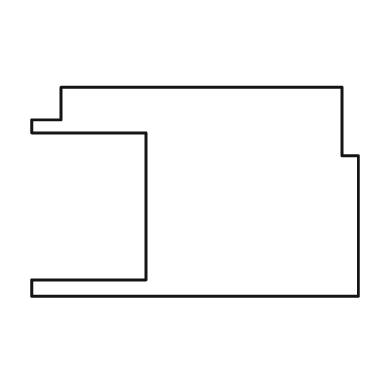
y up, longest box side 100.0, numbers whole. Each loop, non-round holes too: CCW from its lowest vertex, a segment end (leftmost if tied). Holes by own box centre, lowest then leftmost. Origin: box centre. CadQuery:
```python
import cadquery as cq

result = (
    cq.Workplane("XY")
    .moveTo(-50.0, -32.0)
    .lineTo(50.0, -32.0)
    .lineTo(50.0, 11.0)
    .lineTo(45.0, 11.0)
    .lineTo(45.0, 32.0)
    .lineTo(-41.0, 32.0)
    .lineTo(-41.0, 22.0)
    .lineTo(-50.0, 22.0)
    .lineTo(-50.0, 18.0)
    .lineTo(-15.0, 18.0)
    .lineTo(-15.0, -27.0)
    .lineTo(-50.0, -27.0)
    .close()
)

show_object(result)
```